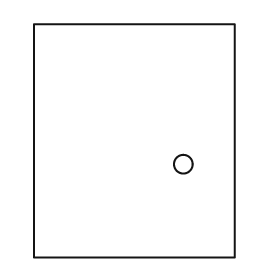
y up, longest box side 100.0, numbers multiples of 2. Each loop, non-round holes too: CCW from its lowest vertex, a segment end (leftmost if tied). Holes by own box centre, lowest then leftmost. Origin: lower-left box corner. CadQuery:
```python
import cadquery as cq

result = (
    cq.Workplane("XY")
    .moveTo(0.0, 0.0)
    .lineTo(86.0, 0.0)
    .lineTo(86.0, 100.0)
    .lineTo(0.0, 100.0)
    .close()
    .moveTo(64.0, 40.0)
    .circle(4.0)
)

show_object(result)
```